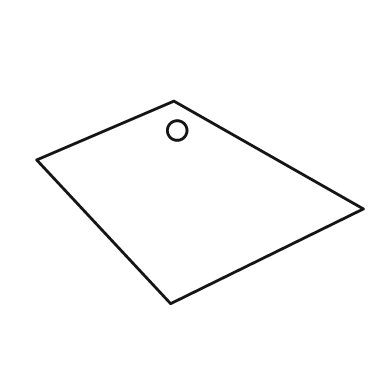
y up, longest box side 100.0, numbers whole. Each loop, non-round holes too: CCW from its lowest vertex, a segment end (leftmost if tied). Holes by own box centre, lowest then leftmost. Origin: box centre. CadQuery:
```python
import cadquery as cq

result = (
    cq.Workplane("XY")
    .moveTo(-9.0, -31.0)
    .lineTo(50.0, -2.0)
    .lineTo(-8.0, 31.0)
    .lineTo(-50.0, 13.0)
    .close()
    .moveTo(-7.0, 22.0)
    .circle(3.0)
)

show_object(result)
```